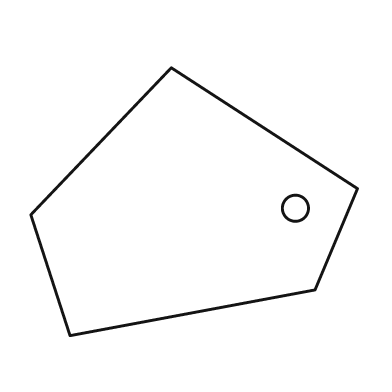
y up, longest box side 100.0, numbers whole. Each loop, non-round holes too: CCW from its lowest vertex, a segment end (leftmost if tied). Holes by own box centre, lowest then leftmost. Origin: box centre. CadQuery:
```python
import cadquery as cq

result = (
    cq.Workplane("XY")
    .moveTo(-38.0, -41.0)
    .lineTo(37.0, -27.0)
    .lineTo(50.0, 4.0)
    .lineTo(-7.0, 41.0)
    .lineTo(-50.0, -4.0)
    .close()
    .moveTo(31.0, -2.0)
    .circle(4.0)
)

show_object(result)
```